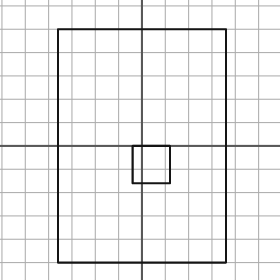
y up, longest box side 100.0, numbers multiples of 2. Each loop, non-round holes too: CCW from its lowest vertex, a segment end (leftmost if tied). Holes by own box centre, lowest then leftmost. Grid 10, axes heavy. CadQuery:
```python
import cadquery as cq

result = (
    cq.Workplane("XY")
    .moveTo(-36.0, -50.0)
    .lineTo(36.0, -50.0)
    .lineTo(36.0, 50.0)
    .lineTo(-36.0, 50.0)
    .close()
    .moveTo(-4.0, -16.0)
    .lineTo(12.0, -16.0)
    .lineTo(12.0, 0.0)
    .lineTo(-4.0, 0.0)
    .close()
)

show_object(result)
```